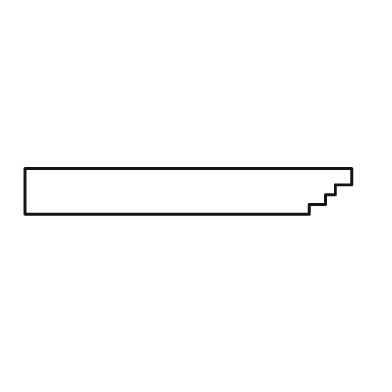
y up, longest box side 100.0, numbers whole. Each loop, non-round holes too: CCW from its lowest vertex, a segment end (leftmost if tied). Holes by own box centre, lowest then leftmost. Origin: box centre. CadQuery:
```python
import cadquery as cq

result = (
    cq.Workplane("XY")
    .moveTo(-50.0, -7.0)
    .lineTo(37.0, -7.0)
    .lineTo(37.0, -4.0)
    .lineTo(42.0, -4.0)
    .lineTo(42.0, -1.0)
    .lineTo(45.0, -1.0)
    .lineTo(45.0, 2.0)
    .lineTo(50.0, 2.0)
    .lineTo(50.0, 7.0)
    .lineTo(-50.0, 7.0)
    .close()
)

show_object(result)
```